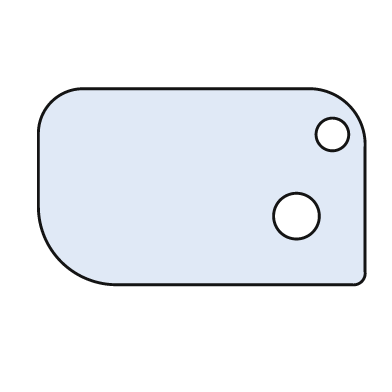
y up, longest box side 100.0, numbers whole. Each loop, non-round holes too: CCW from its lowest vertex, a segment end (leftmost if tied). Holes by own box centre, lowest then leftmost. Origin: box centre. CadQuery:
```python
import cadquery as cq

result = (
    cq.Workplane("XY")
    .moveTo(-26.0, -30.0)
    .lineTo(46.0, -30.0)
    .threePointArc((49.0, -29.0), (50.0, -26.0))
    .lineTo(50.0, 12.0)
    .threePointArc((45.0, 25.0), (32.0, 30.0))
    .lineTo(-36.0, 30.0)
    .threePointArc((-46.0, 26.0), (-50.0, 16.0))
    .lineTo(-50.0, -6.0)
    .threePointArc((-43.0, -23.0), (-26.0, -30.0))
    .close()
    .moveTo(29.0, -9.0)
    .circle(7.0)
    .moveTo(40.0, 16.0)
    .circle(5.0)
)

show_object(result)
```